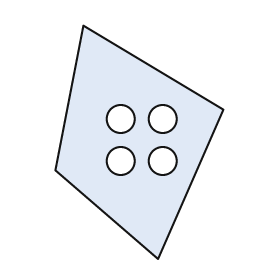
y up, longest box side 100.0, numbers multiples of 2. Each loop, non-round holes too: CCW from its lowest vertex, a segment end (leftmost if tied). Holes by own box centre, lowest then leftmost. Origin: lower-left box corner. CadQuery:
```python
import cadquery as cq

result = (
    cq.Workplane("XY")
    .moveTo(44.0, 0.0)
    .lineTo(72.0, 64.0)
    .lineTo(12.0, 100.0)
    .lineTo(0.0, 38.0)
    .close()
    .moveTo(28.0, 42.0)
    .circle(6.0)
    .moveTo(46.0, 42.0)
    .circle(6.0)
    .moveTo(28.0, 60.0)
    .circle(6.0)
    .moveTo(46.0, 60.0)
    .circle(6.0)
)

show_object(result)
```